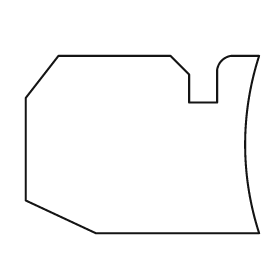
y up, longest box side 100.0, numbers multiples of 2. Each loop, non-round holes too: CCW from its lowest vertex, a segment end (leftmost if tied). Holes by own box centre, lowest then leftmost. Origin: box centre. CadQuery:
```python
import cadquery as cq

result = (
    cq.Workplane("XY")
    .moveTo(-20.0, -38.0)
    .lineTo(50.0, -38.0)
    .threePointArc((44.0, 0.0), (50.0, 38.0))
    .lineTo(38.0, 38.0)
    .threePointArc((34.0, 36.0), (32.0, 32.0))
    .lineTo(32.0, 18.0)
    .lineTo(20.0, 18.0)
    .lineTo(20.0, 30.0)
    .lineTo(12.0, 38.0)
    .lineTo(-36.0, 38.0)
    .lineTo(-50.0, 20.0)
    .lineTo(-50.0, -24.0)
    .close()
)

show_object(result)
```